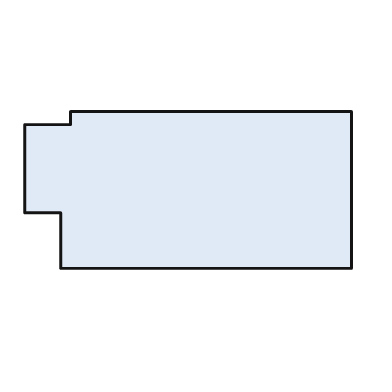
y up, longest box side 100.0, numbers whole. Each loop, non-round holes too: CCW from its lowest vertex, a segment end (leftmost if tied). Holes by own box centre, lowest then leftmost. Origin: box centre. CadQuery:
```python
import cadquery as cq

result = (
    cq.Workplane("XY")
    .moveTo(-39.0, -24.0)
    .lineTo(50.0, -24.0)
    .lineTo(50.0, 24.0)
    .lineTo(-36.0, 24.0)
    .lineTo(-36.0, 20.0)
    .lineTo(-50.0, 20.0)
    .lineTo(-50.0, -7.0)
    .lineTo(-39.0, -7.0)
    .close()
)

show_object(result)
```